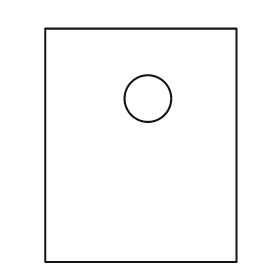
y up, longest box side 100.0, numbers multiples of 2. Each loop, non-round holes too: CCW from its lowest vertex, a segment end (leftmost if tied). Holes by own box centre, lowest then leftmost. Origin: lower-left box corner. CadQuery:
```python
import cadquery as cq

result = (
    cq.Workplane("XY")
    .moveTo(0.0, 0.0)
    .lineTo(82.0, 0.0)
    .lineTo(82.0, 100.0)
    .lineTo(0.0, 100.0)
    .close()
    .moveTo(44.0, 70.0)
    .circle(10.0)
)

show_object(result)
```